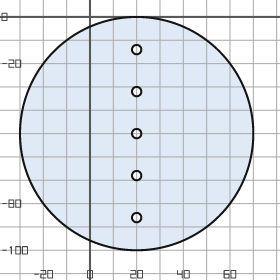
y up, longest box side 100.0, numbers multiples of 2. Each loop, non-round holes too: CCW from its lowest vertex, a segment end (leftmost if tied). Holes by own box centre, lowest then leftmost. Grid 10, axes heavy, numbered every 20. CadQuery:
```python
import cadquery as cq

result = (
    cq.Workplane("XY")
    .moveTo(20.0, -50.0)
    .circle(50.0)
    .moveTo(20.0, -86.0)
    .circle(2.0)
    .moveTo(20.0, -68.0)
    .circle(2.0)
    .moveTo(20.0, -50.0)
    .circle(2.0)
    .moveTo(20.0, -32.0)
    .circle(2.0)
    .moveTo(20.0, -14.0)
    .circle(2.0)
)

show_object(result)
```